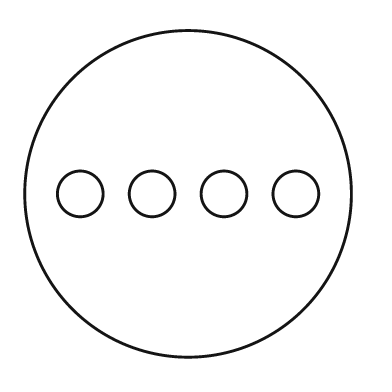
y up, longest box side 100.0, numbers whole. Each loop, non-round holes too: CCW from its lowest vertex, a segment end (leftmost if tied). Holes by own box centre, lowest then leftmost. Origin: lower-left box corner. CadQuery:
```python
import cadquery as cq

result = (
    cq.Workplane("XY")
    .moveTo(50.0, 50.0)
    .circle(50.0)
    .moveTo(17.0, 50.0)
    .circle(7.0)
    .moveTo(39.0, 50.0)
    .circle(7.0)
    .moveTo(61.0, 50.0)
    .circle(7.0)
    .moveTo(83.0, 50.0)
    .circle(7.0)
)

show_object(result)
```